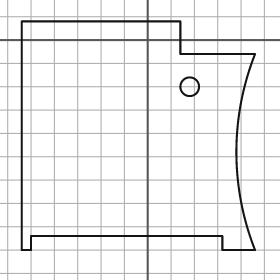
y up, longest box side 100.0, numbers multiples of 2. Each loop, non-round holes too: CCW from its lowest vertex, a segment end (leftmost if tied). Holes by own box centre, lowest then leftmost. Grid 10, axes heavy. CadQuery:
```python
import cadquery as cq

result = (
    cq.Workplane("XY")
    .moveTo(-54.0, -90.0)
    .lineTo(-50.0, -90.0)
    .lineTo(-50.0, -84.0)
    .lineTo(32.0, -84.0)
    .lineTo(32.0, -90.0)
    .lineTo(46.0, -90.0)
    .threePointArc((38.0, -48.0), (46.0, -6.0))
    .lineTo(14.0, -6.0)
    .lineTo(14.0, 8.0)
    .lineTo(-54.0, 8.0)
    .close()
    .moveTo(18.0, -20.0)
    .circle(4.0)
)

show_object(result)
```